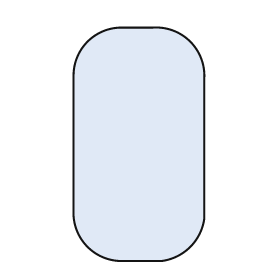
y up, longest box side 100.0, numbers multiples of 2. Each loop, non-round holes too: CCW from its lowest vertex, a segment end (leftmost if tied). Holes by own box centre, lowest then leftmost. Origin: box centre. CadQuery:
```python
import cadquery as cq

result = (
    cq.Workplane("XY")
    .moveTo(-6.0, -50.0)
    .lineTo(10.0, -50.0)
    .threePointArc((22.0, -44.0), (28.0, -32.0))
    .lineTo(28.0, 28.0)
    .threePointArc((22.0, 44.0), (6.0, 50.0))
    .lineTo(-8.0, 50.0)
    .threePointArc((-22.0, 44.0), (-28.0, 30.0))
    .lineTo(-28.0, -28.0)
    .threePointArc((-22.0, -44.0), (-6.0, -50.0))
    .close()
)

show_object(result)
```